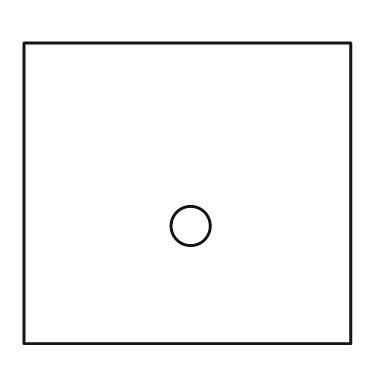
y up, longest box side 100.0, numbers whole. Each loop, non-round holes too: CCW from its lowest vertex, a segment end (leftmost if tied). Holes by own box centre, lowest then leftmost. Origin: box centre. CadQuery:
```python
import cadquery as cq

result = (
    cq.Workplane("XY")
    .moveTo(-50.0, -46.0)
    .lineTo(50.0, -46.0)
    .lineTo(50.0, 46.0)
    .lineTo(-50.0, 46.0)
    .close()
    .moveTo(1.0, -10.0)
    .circle(6.0)
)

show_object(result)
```